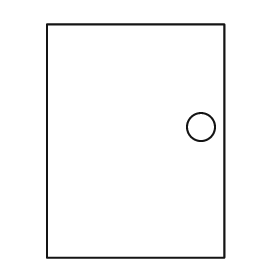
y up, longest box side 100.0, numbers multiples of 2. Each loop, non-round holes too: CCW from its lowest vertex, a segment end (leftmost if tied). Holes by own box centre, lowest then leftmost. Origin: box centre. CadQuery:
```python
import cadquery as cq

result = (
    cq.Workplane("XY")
    .moveTo(-38.0, -50.0)
    .lineTo(38.0, -50.0)
    .lineTo(38.0, 50.0)
    .lineTo(-38.0, 50.0)
    .close()
    .moveTo(28.0, 6.0)
    .circle(6.0)
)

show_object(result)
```